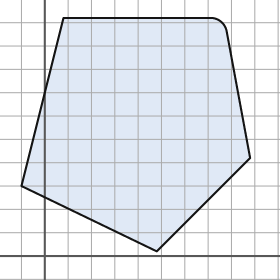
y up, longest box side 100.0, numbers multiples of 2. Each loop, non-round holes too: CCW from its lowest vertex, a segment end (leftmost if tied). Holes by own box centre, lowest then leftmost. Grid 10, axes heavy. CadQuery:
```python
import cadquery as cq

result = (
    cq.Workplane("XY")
    .moveTo(48.0, 2.0)
    .lineTo(88.0, 42.0)
    .lineTo(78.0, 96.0)
    .threePointArc((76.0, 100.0), (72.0, 102.0))
    .lineTo(8.0, 102.0)
    .lineTo(-10.0, 30.0)
    .close()
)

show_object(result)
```